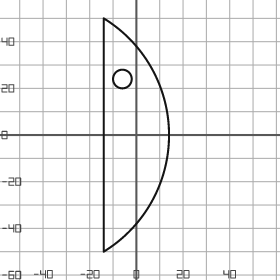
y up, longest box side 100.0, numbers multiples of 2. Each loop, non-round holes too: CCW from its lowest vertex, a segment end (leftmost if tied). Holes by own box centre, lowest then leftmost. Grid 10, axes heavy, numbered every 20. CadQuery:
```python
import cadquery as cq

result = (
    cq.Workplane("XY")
    .moveTo(-14.0, -50.0)
    .threePointArc((14.0, 0.0), (-14.0, 50.0))
    .close()
    .moveTo(-6.0, 24.0)
    .circle(4.0)
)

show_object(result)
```